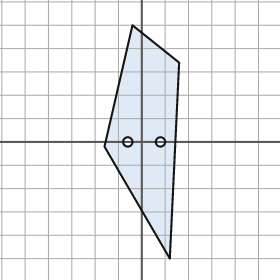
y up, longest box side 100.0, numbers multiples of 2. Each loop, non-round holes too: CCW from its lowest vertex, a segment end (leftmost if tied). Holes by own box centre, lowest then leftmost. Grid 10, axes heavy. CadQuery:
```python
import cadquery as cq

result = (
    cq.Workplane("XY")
    .moveTo(12.0, -50.0)
    .lineTo(16.0, 34.0)
    .lineTo(-4.0, 50.0)
    .lineTo(-16.0, -2.0)
    .close()
    .moveTo(-6.0, 0.0)
    .circle(2.0)
    .moveTo(8.0, 0.0)
    .circle(2.0)
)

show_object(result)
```